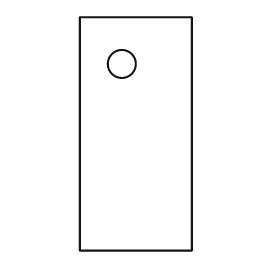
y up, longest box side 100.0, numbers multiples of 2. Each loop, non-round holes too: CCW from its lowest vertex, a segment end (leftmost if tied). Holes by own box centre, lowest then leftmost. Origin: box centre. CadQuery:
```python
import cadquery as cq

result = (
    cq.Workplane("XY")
    .moveTo(-24.0, -50.0)
    .lineTo(24.0, -50.0)
    .lineTo(24.0, 50.0)
    .lineTo(-24.0, 50.0)
    .close()
    .moveTo(-6.0, 30.0)
    .circle(6.0)
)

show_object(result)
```